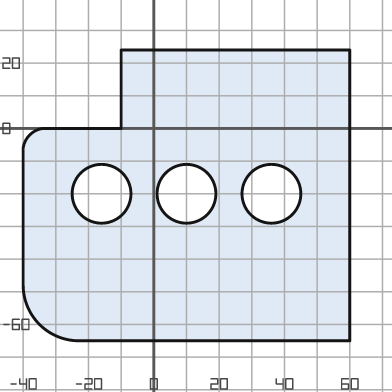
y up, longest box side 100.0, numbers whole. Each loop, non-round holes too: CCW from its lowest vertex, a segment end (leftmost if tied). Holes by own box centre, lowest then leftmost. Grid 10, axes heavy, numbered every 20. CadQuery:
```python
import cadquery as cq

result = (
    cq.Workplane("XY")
    .moveTo(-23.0, -65.0)
    .lineTo(60.0, -65.0)
    .lineTo(60.0, 24.0)
    .lineTo(-10.0, 24.0)
    .lineTo(-10.0, 0.0)
    .lineTo(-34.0, 0.0)
    .threePointArc((-38.0, -2.0), (-40.0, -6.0))
    .lineTo(-40.0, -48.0)
    .threePointArc((-35.0, -60.0), (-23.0, -65.0))
    .close()
    .moveTo(-16.0, -20.0)
    .circle(9.0)
    .moveTo(10.0, -20.0)
    .circle(9.0)
    .moveTo(36.0, -20.0)
    .circle(9.0)
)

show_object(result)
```